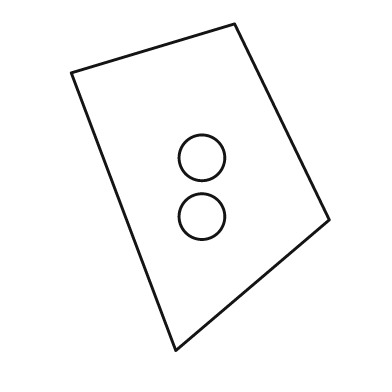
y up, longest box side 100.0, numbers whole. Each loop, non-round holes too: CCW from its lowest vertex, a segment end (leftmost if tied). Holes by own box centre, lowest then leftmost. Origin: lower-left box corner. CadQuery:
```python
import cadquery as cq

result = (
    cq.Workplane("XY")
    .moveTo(32.0, 0.0)
    .lineTo(79.0, 40.0)
    .lineTo(50.0, 100.0)
    .lineTo(0.0, 85.0)
    .close()
    .moveTo(40.0, 41.0)
    .circle(7.0)
    .moveTo(40.0, 59.0)
    .circle(7.0)
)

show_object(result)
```